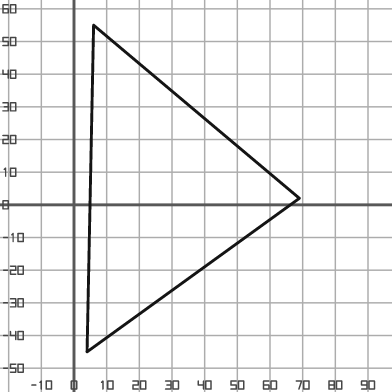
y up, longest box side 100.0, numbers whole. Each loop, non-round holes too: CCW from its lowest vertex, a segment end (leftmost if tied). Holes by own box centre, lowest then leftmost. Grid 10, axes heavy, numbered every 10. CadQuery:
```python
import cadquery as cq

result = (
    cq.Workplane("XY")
    .moveTo(4.0, -45.0)
    .lineTo(69.0, 2.0)
    .lineTo(6.0, 55.0)
    .close()
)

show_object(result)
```